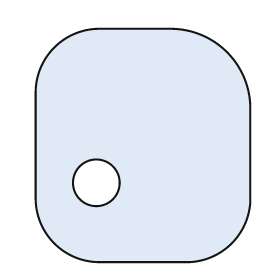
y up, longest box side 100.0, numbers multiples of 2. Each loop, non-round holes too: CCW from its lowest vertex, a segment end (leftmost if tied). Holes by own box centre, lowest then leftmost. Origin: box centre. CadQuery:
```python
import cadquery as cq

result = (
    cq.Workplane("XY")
    .moveTo(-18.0, -50.0)
    .lineTo(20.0, -50.0)
    .threePointArc((38.0, -42.0), (46.0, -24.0))
    .lineTo(46.0, 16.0)
    .threePointArc((36.0, 40.0), (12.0, 50.0))
    .lineTo(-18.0, 50.0)
    .threePointArc((-38.0, 42.0), (-46.0, 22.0))
    .lineTo(-46.0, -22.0)
    .threePointArc((-38.0, -42.0), (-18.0, -50.0))
    .close()
    .moveTo(-20.0, -16.0)
    .circle(10.0)
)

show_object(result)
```